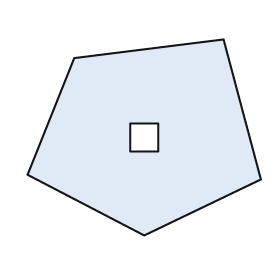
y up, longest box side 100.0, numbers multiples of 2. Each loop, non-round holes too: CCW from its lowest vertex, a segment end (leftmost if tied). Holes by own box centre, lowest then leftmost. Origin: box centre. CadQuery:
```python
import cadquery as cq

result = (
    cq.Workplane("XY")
    .moveTo(0.0, -42.0)
    .lineTo(50.0, -18.0)
    .lineTo(34.0, 42.0)
    .lineTo(-30.0, 34.0)
    .lineTo(-50.0, -16.0)
    .close()
    .moveTo(-6.0, -6.0)
    .lineTo(6.0, -6.0)
    .lineTo(6.0, 6.0)
    .lineTo(-6.0, 6.0)
    .close()
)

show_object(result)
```